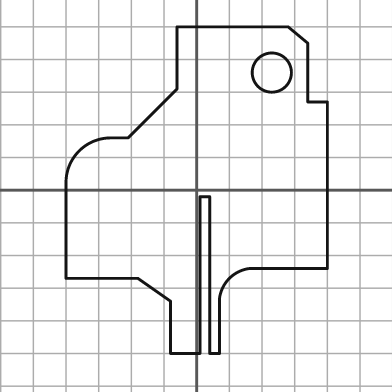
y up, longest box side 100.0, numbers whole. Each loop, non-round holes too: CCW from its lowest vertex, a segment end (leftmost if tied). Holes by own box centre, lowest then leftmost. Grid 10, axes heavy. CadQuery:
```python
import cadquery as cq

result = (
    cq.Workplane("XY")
    .moveTo(-8.0, -50.0)
    .lineTo(1.0, -50.0)
    .lineTo(1.0, -2.0)
    .lineTo(4.0, -2.0)
    .lineTo(4.0, -50.0)
    .lineTo(7.0, -50.0)
    .lineTo(7.0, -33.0)
    .threePointArc((10.0, -27.0), (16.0, -24.0))
    .lineTo(40.0, -24.0)
    .lineTo(40.0, 27.0)
    .lineTo(34.0, 27.0)
    .lineTo(34.0, 45.0)
    .lineTo(28.0, 50.0)
    .lineTo(-6.0, 50.0)
    .lineTo(-6.0, 31.0)
    .lineTo(-21.0, 16.0)
    .lineTo(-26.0, 16.0)
    .threePointArc((-36.0, 12.0), (-40.0, 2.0))
    .lineTo(-40.0, -27.0)
    .lineTo(-18.0, -27.0)
    .lineTo(-8.0, -34.0)
    .close()
    .moveTo(23.0, 36.0)
    .circle(6.0)
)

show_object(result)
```